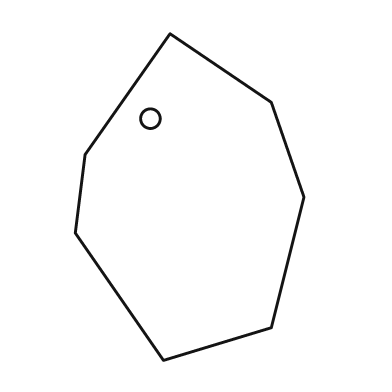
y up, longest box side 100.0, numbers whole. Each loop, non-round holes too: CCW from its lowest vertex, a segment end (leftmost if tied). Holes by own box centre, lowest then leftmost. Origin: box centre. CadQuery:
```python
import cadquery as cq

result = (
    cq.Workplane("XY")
    .moveTo(-8.0, -50.0)
    .lineTo(25.0, -40.0)
    .lineTo(35.0, 0.0)
    .lineTo(25.0, 29.0)
    .lineTo(-6.0, 50.0)
    .lineTo(-32.0, 13.0)
    .lineTo(-35.0, -11.0)
    .close()
    .moveTo(-12.0, 24.0)
    .circle(3.0)
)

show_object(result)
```